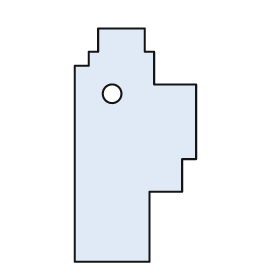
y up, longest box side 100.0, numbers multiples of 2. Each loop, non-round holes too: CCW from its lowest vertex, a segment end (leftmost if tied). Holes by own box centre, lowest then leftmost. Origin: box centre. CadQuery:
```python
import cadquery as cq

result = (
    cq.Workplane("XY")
    .moveTo(-26.0, -50.0)
    .lineTo(6.0, -50.0)
    .lineTo(6.0, -20.0)
    .lineTo(20.0, -20.0)
    .lineTo(20.0, -6.0)
    .lineTo(26.0, -6.0)
    .lineTo(26.0, 26.0)
    .lineTo(8.0, 26.0)
    .lineTo(8.0, 40.0)
    .lineTo(4.0, 40.0)
    .lineTo(4.0, 50.0)
    .lineTo(-16.0, 50.0)
    .lineTo(-16.0, 40.0)
    .lineTo(-20.0, 40.0)
    .lineTo(-20.0, 34.0)
    .lineTo(-26.0, 34.0)
    .close()
    .moveTo(-10.0, 22.0)
    .circle(4.0)
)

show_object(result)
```